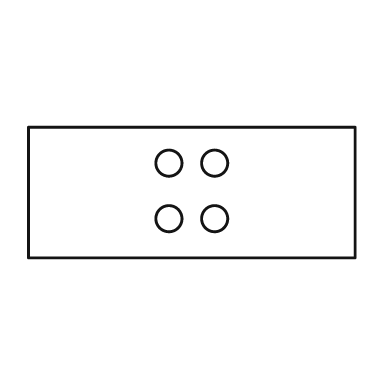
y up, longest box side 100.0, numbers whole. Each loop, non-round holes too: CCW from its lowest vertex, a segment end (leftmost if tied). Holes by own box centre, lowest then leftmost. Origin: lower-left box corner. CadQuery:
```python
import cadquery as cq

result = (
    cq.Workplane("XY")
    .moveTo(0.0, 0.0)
    .lineTo(100.0, 0.0)
    .lineTo(100.0, 40.0)
    .lineTo(0.0, 40.0)
    .close()
    .moveTo(43.0, 12.0)
    .circle(4.0)
    .moveTo(57.0, 12.0)
    .circle(4.0)
    .moveTo(43.0, 29.0)
    .circle(4.0)
    .moveTo(57.0, 29.0)
    .circle(4.0)
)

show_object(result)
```